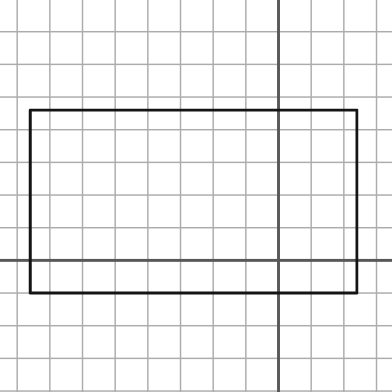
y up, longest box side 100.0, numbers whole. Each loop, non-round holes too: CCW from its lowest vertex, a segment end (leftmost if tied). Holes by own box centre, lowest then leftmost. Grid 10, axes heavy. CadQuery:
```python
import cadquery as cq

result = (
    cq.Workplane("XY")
    .moveTo(-76.0, -10.0)
    .lineTo(24.0, -10.0)
    .lineTo(24.0, 46.0)
    .lineTo(-76.0, 46.0)
    .close()
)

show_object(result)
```